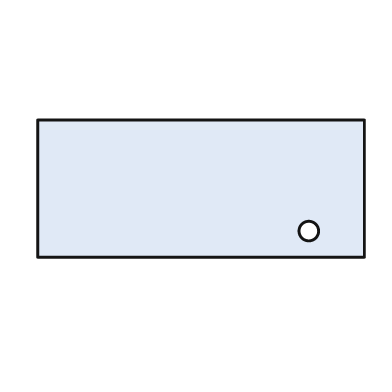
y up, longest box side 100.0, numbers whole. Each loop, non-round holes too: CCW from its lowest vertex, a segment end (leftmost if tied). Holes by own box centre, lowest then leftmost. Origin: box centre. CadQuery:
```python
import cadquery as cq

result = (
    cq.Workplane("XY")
    .moveTo(-50.0, -21.0)
    .lineTo(50.0, -21.0)
    .lineTo(50.0, 21.0)
    .lineTo(-50.0, 21.0)
    .close()
    .moveTo(33.0, -13.0)
    .circle(3.0)
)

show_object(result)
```